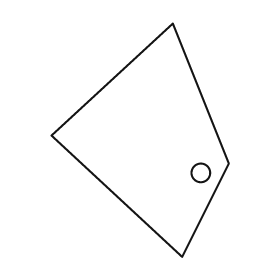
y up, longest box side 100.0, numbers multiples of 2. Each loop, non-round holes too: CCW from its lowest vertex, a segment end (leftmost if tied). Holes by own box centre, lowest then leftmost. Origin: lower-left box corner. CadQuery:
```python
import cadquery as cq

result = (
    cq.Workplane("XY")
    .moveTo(56.0, 0.0)
    .lineTo(76.0, 40.0)
    .lineTo(52.0, 100.0)
    .lineTo(0.0, 52.0)
    .close()
    .moveTo(64.0, 36.0)
    .circle(4.0)
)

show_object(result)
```